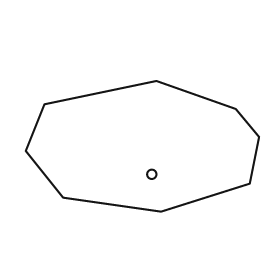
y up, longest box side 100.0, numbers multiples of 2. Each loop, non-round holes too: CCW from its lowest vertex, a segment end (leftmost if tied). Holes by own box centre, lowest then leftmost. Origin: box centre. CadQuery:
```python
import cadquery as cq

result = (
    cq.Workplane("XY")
    .moveTo(8.0, -28.0)
    .lineTo(46.0, -16.0)
    .lineTo(50.0, 4.0)
    .lineTo(40.0, 16.0)
    .lineTo(6.0, 28.0)
    .lineTo(-42.0, 18.0)
    .lineTo(-50.0, -2.0)
    .lineTo(-34.0, -22.0)
    .close()
    .moveTo(4.0, -12.0)
    .circle(2.0)
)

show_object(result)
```